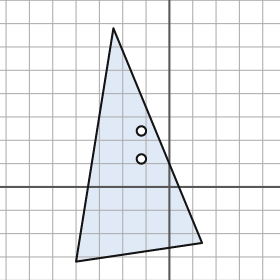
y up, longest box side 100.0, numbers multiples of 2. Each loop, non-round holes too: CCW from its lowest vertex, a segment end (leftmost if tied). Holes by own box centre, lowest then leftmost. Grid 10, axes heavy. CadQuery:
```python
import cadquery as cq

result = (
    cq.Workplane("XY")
    .moveTo(-40.0, -32.0)
    .lineTo(14.0, -24.0)
    .lineTo(-24.0, 68.0)
    .close()
    .moveTo(-12.0, 12.0)
    .circle(2.0)
    .moveTo(-12.0, 24.0)
    .circle(2.0)
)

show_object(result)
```